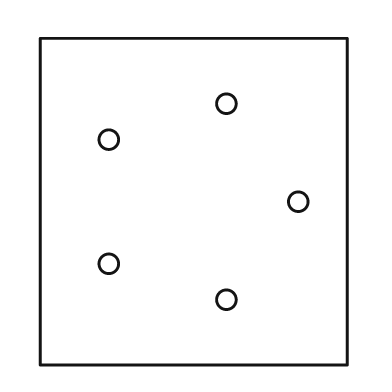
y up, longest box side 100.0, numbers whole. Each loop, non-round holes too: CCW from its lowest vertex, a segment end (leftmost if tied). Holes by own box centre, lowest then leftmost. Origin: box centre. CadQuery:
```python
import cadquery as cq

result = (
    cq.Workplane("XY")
    .moveTo(-47.0, -50.0)
    .lineTo(47.0, -50.0)
    .lineTo(47.0, 50.0)
    .lineTo(-47.0, 50.0)
    .close()
    .moveTo(10.0, -30.0)
    .circle(3.0)
    .moveTo(-26.0, -19.0)
    .circle(3.0)
    .moveTo(32.0, 0.0)
    .circle(3.0)
    .moveTo(-26.0, 19.0)
    .circle(3.0)
    .moveTo(10.0, 30.0)
    .circle(3.0)
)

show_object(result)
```